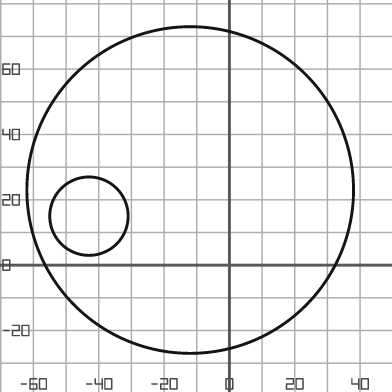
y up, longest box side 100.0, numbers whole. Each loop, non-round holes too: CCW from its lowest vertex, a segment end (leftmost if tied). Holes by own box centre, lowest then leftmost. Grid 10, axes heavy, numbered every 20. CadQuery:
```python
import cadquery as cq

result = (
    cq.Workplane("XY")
    .moveTo(-12.0, 23.0)
    .circle(50.0)
    .moveTo(-43.0, 15.0)
    .circle(12.0)
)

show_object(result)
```